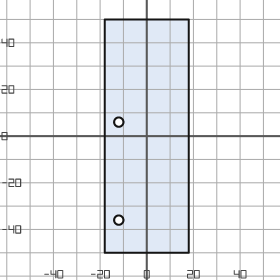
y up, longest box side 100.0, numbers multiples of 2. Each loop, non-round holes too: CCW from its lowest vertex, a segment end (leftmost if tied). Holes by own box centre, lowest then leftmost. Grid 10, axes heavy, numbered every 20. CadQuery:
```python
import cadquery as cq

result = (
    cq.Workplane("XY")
    .moveTo(-18.0, -50.0)
    .lineTo(18.0, -50.0)
    .lineTo(18.0, 50.0)
    .lineTo(-18.0, 50.0)
    .close()
    .moveTo(-12.0, -36.0)
    .circle(2.0)
    .moveTo(-12.0, 6.0)
    .circle(2.0)
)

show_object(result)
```